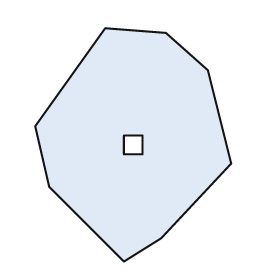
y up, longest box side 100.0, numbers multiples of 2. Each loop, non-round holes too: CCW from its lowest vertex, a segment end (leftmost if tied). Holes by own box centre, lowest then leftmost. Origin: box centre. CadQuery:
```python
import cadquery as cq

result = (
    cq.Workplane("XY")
    .moveTo(-4.0, -50.0)
    .lineTo(12.0, -40.0)
    .lineTo(42.0, -8.0)
    .lineTo(32.0, 32.0)
    .lineTo(14.0, 48.0)
    .lineTo(-12.0, 50.0)
    .lineTo(-42.0, 8.0)
    .lineTo(-36.0, -18.0)
    .close()
    .moveTo(-4.0, -4.0)
    .lineTo(4.0, -4.0)
    .lineTo(4.0, 4.0)
    .lineTo(-4.0, 4.0)
    .close()
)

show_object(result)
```